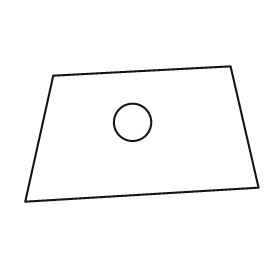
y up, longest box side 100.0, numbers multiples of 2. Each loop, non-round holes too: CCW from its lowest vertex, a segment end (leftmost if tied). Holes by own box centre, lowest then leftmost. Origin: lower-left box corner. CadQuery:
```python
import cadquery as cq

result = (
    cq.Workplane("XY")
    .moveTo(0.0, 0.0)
    .lineTo(100.0, 6.0)
    .lineTo(88.0, 58.0)
    .lineTo(12.0, 54.0)
    .close()
    .moveTo(46.0, 34.0)
    .circle(8.0)
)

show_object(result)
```